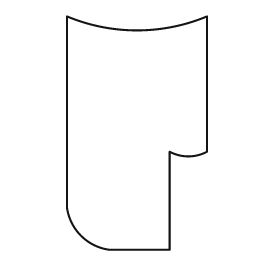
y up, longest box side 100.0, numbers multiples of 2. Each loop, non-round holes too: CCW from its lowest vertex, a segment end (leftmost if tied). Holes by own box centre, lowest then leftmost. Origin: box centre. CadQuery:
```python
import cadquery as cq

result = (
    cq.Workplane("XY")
    .moveTo(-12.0, -50.0)
    .lineTo(14.0, -50.0)
    .lineTo(14.0, -8.0)
    .threePointArc((22.0, -10.0), (30.0, -8.0))
    .lineTo(30.0, 50.0)
    .threePointArc((0.0, 44.0), (-30.0, 50.0))
    .lineTo(-30.0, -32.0)
    .threePointArc((-24.0, -44.0), (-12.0, -50.0))
    .close()
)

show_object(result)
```